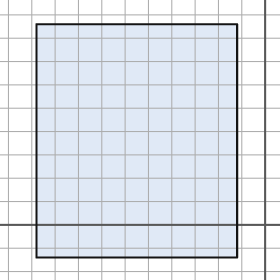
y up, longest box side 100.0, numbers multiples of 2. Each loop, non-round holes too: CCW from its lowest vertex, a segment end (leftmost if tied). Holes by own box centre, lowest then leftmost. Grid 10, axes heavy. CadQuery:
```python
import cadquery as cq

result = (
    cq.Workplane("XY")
    .moveTo(-98.0, -14.0)
    .lineTo(-12.0, -14.0)
    .lineTo(-12.0, 86.0)
    .lineTo(-98.0, 86.0)
    .close()
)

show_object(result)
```